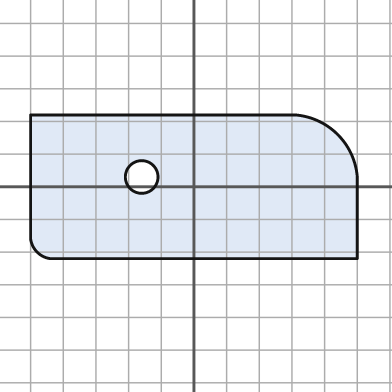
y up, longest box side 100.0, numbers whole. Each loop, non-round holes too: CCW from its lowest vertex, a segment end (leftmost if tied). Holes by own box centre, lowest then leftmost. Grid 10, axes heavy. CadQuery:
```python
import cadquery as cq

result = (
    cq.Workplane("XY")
    .moveTo(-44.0, -22.0)
    .lineTo(50.0, -22.0)
    .lineTo(50.0, 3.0)
    .threePointArc((44.0, 16.0), (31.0, 22.0))
    .lineTo(-50.0, 22.0)
    .lineTo(-50.0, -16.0)
    .threePointArc((-48.0, -20.0), (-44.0, -22.0))
    .close()
    .moveTo(-16.0, 3.0)
    .circle(5.0)
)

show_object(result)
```